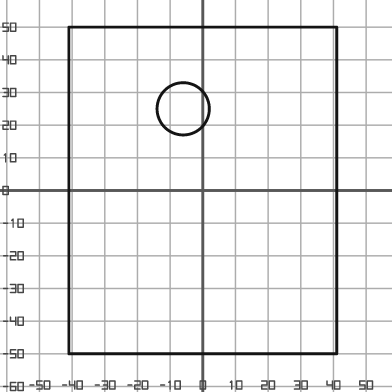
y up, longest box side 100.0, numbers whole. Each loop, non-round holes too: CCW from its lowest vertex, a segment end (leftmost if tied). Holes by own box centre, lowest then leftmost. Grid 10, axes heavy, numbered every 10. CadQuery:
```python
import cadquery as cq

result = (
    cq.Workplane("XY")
    .moveTo(-41.0, -50.0)
    .lineTo(41.0, -50.0)
    .lineTo(41.0, 50.0)
    .lineTo(-41.0, 50.0)
    .close()
    .moveTo(-6.0, 25.0)
    .circle(8.0)
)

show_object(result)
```